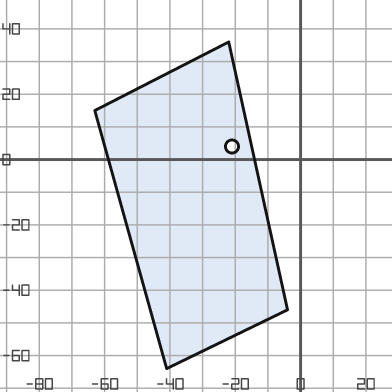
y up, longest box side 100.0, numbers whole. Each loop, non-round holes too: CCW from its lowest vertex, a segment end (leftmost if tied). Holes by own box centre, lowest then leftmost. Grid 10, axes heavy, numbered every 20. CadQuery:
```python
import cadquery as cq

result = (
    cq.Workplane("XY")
    .moveTo(-41.0, -64.0)
    .lineTo(-4.0, -46.0)
    .lineTo(-22.0, 36.0)
    .lineTo(-63.0, 15.0)
    .close()
    .moveTo(-21.0, 4.0)
    .circle(2.0)
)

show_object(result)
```